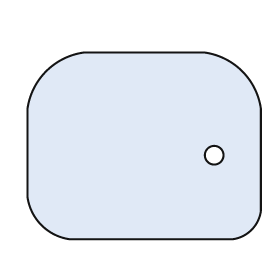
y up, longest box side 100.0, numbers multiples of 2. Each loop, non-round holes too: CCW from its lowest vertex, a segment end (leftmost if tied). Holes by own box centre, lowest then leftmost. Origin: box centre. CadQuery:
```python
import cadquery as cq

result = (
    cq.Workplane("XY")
    .moveTo(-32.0, -40.0)
    .lineTo(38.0, -40.0)
    .threePointArc((46.0, -36.0), (50.0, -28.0))
    .lineTo(50.0, 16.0)
    .threePointArc((42.0, 32.0), (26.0, 40.0))
    .lineTo(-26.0, 40.0)
    .threePointArc((-42.0, 32.0), (-50.0, 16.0))
    .lineTo(-50.0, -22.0)
    .threePointArc((-44.0, -34.0), (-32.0, -40.0))
    .close()
    .moveTo(30.0, -4.0)
    .circle(4.0)
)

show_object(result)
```